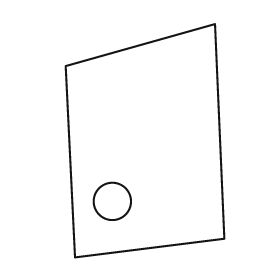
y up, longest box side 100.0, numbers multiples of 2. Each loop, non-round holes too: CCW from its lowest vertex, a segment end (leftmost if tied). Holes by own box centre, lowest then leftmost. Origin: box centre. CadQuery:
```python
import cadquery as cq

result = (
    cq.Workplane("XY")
    .moveTo(-30.0, -50.0)
    .lineTo(34.0, -42.0)
    .lineTo(30.0, 50.0)
    .lineTo(-34.0, 32.0)
    .close()
    .moveTo(-14.0, -26.0)
    .circle(8.0)
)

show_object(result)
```